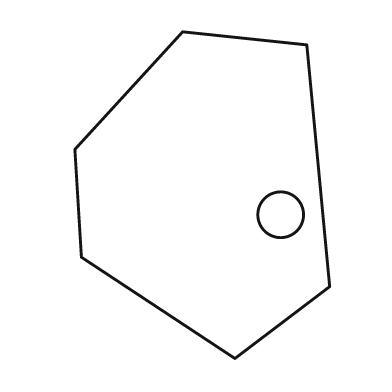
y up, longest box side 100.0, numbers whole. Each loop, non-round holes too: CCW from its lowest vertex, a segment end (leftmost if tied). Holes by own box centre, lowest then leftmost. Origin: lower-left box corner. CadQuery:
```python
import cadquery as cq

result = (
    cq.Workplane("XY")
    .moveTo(49.0, 0.0)
    .lineTo(78.0, 22.0)
    .lineTo(71.0, 96.0)
    .lineTo(33.0, 100.0)
    .lineTo(0.0, 64.0)
    .lineTo(2.0, 31.0)
    .close()
    .moveTo(63.0, 44.0)
    .circle(7.0)
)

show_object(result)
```